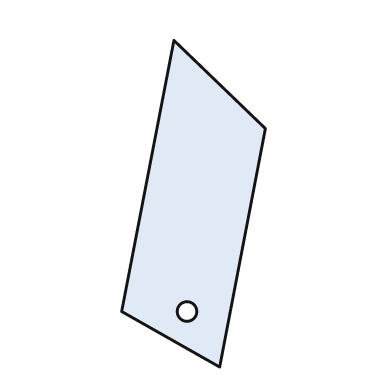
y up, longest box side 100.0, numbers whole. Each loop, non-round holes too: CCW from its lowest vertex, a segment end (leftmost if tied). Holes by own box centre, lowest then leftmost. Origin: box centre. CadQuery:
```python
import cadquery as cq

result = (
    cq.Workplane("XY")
    .moveTo(8.0, -50.0)
    .lineTo(22.0, 23.0)
    .lineTo(-6.0, 50.0)
    .lineTo(-22.0, -33.0)
    .close()
    .moveTo(-2.0, -33.0)
    .circle(3.0)
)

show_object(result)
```